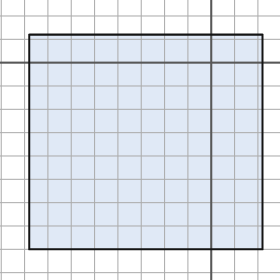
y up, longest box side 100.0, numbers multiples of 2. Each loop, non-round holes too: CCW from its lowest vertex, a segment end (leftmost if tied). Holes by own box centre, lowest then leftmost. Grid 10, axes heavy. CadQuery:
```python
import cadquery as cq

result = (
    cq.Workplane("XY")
    .moveTo(-78.0, -80.0)
    .lineTo(22.0, -80.0)
    .lineTo(22.0, 12.0)
    .lineTo(-78.0, 12.0)
    .close()
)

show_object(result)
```